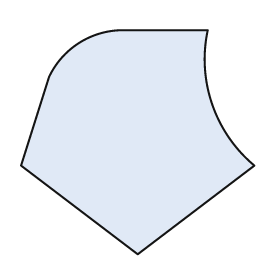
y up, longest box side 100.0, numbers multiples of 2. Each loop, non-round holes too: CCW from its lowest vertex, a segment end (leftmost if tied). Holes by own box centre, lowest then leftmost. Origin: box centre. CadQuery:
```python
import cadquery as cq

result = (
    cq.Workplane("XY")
    .moveTo(0.0, -48.0)
    .lineTo(50.0, -10.0)
    .threePointArc((32.0, 16.0), (30.0, 48.0))
    .lineTo(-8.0, 48.0)
    .threePointArc((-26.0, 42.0), (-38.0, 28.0))
    .lineTo(-50.0, -10.0)
    .close()
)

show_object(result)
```